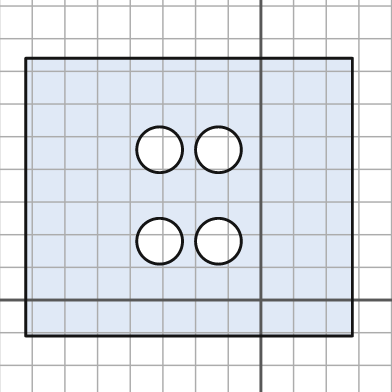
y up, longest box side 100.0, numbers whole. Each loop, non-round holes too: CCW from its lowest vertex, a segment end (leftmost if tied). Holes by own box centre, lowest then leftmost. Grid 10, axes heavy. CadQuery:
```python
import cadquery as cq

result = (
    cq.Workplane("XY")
    .moveTo(-72.0, -11.0)
    .lineTo(28.0, -11.0)
    .lineTo(28.0, 74.0)
    .lineTo(-72.0, 74.0)
    .close()
    .moveTo(-31.0, 18.0)
    .circle(7.0)
    .moveTo(-13.0, 18.0)
    .circle(7.0)
    .moveTo(-31.0, 46.0)
    .circle(7.0)
    .moveTo(-13.0, 46.0)
    .circle(7.0)
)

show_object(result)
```